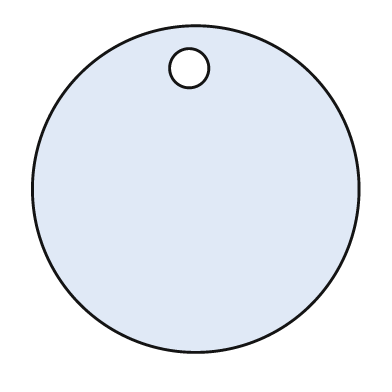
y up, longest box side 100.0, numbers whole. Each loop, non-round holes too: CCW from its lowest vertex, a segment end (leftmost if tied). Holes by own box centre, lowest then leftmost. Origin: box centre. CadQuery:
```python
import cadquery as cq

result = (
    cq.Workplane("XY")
    .moveTo(0.0, 0.0)
    .circle(50.0)
    .moveTo(-2.0, 37.0)
    .circle(6.0)
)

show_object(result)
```